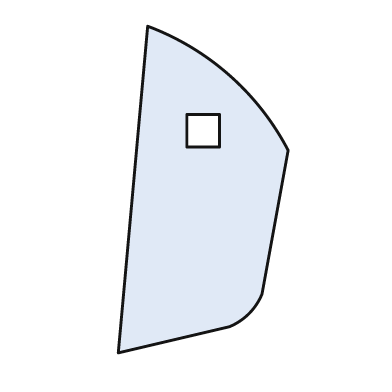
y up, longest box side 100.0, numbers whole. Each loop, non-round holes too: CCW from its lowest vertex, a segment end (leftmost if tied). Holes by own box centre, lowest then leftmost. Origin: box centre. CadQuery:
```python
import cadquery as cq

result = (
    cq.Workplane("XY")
    .moveTo(-26.0, -50.0)
    .lineTo(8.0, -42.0)
    .threePointArc((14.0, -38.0), (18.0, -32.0))
    .lineTo(26.0, 12.0)
    .threePointArc((8.0, 35.0), (-17.0, 50.0))
    .close()
    .moveTo(-5.0, 13.0)
    .lineTo(5.0, 13.0)
    .lineTo(5.0, 23.0)
    .lineTo(-5.0, 23.0)
    .close()
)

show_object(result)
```